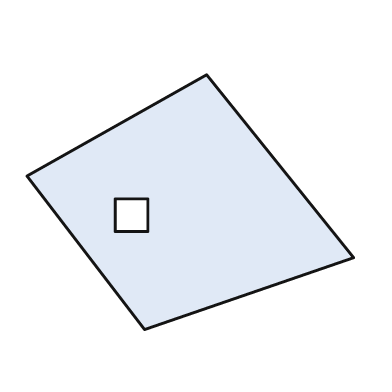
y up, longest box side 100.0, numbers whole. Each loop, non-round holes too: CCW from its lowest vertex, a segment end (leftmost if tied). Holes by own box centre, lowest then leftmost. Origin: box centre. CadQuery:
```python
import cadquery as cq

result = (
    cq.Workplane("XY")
    .moveTo(-14.0, -39.0)
    .lineTo(50.0, -17.0)
    .lineTo(5.0, 39.0)
    .lineTo(-50.0, 8.0)
    .close()
    .moveTo(-23.0, -9.0)
    .lineTo(-13.0, -9.0)
    .lineTo(-13.0, 1.0)
    .lineTo(-23.0, 1.0)
    .close()
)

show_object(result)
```